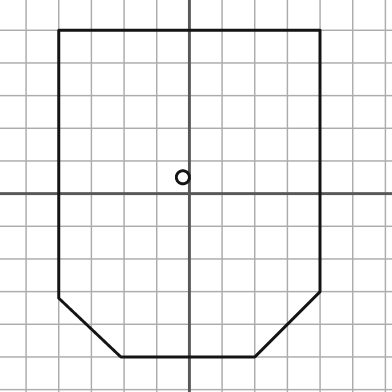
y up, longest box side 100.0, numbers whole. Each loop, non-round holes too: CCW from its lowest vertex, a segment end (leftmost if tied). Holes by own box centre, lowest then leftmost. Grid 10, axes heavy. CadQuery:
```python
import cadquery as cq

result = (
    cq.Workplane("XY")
    .moveTo(-21.0, -50.0)
    .lineTo(20.0, -50.0)
    .lineTo(40.0, -30.0)
    .lineTo(40.0, 50.0)
    .lineTo(-40.0, 50.0)
    .lineTo(-40.0, -32.0)
    .close()
    .moveTo(-2.0, 5.0)
    .circle(2.0)
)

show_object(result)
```